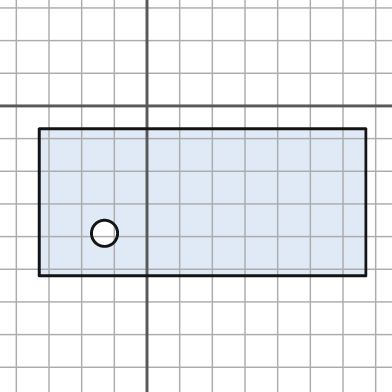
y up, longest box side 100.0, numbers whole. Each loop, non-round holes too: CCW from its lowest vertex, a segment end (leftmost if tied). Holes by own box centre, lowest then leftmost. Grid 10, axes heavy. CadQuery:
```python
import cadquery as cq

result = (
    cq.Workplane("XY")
    .moveTo(-33.0, -52.0)
    .lineTo(67.0, -52.0)
    .lineTo(67.0, -7.0)
    .lineTo(-33.0, -7.0)
    .close()
    .moveTo(-13.0, -39.0)
    .circle(4.0)
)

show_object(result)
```